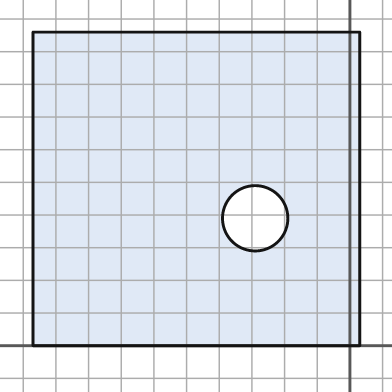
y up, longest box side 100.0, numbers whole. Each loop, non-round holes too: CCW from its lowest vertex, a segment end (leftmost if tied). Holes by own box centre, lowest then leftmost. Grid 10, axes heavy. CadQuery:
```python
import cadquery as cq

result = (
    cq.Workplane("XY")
    .moveTo(-97.0, 0.0)
    .lineTo(3.0, 0.0)
    .lineTo(3.0, 96.0)
    .lineTo(-97.0, 96.0)
    .close()
    .moveTo(-29.0, 39.0)
    .circle(10.0)
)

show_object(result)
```